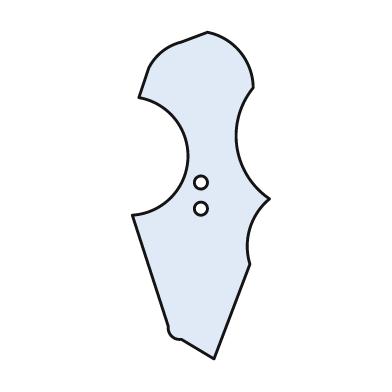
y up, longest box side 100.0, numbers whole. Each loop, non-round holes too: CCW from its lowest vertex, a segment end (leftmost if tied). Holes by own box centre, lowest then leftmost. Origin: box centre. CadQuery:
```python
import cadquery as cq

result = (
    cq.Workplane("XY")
    .moveTo(4.0, -50.0)
    .lineTo(15.0, -21.0)
    .threePointArc((15.0, -10.0), (21.0, -1.0))
    .threePointArc((11.0, 15.0), (16.0, 33.0))
    .threePointArc((12.0, 44.0), (2.0, 50.0))
    .lineTo(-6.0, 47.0)
    .threePointArc((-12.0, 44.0), (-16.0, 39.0))
    .lineTo(-19.0, 30.0)
    .threePointArc((-4.0, 11.0), (-21.0, -6.0))
    .lineTo(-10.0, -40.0)
    .threePointArc((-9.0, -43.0), (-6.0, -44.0))
    .close()
    .moveTo(0.0, -4.0)
    .circle(2.0)
    .moveTo(0.0, 4.0)
    .circle(2.0)
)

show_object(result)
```